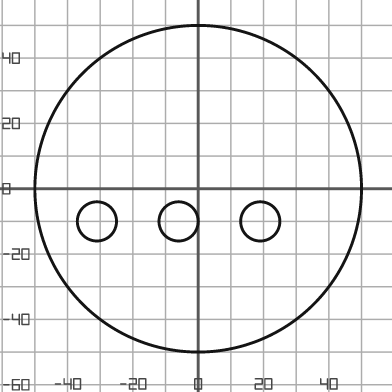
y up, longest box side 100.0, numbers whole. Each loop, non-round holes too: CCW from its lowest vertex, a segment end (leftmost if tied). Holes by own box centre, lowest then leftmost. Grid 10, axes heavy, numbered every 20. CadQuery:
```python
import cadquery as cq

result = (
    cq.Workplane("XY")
    .moveTo(0.0, 0.0)
    .circle(50.0)
    .moveTo(-31.0, -10.0)
    .circle(6.0)
    .moveTo(-6.0, -10.0)
    .circle(6.0)
    .moveTo(19.0, -10.0)
    .circle(6.0)
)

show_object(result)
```